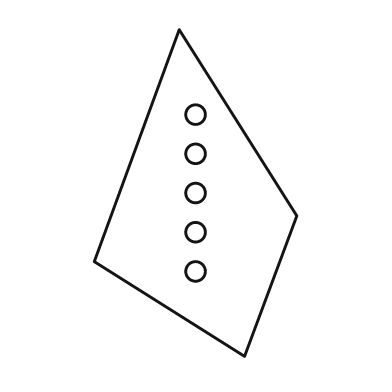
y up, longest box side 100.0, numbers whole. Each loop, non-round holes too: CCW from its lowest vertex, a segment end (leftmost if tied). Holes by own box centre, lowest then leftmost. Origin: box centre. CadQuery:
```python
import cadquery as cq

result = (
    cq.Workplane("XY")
    .moveTo(15.0, -50.0)
    .lineTo(31.0, -7.0)
    .lineTo(-5.0, 50.0)
    .lineTo(-31.0, -21.0)
    .close()
    .moveTo(0.0, -24.0)
    .circle(3.0)
    .moveTo(0.0, -12.0)
    .circle(3.0)
    .moveTo(0.0, 0.0)
    .circle(3.0)
    .moveTo(0.0, 12.0)
    .circle(3.0)
    .moveTo(0.0, 24.0)
    .circle(3.0)
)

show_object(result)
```